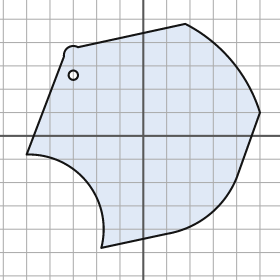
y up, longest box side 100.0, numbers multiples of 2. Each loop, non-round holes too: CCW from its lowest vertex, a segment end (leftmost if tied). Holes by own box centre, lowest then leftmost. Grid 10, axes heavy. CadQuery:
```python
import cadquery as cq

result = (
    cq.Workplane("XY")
    .moveTo(-18.0, -48.0)
    .lineTo(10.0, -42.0)
    .threePointArc((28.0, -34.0), (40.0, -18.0))
    .lineTo(50.0, 10.0)
    .threePointArc((38.0, 32.0), (18.0, 48.0))
    .lineTo(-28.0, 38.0)
    .threePointArc((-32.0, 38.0), (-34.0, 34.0))
    .lineTo(-50.0, -8.0)
    .threePointArc((-24.0, -20.0), (-18.0, -48.0))
    .close()
    .moveTo(-30.0, 26.0)
    .circle(2.0)
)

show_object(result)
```